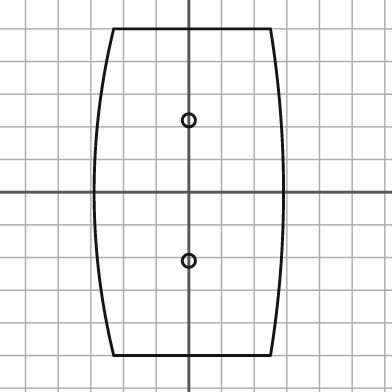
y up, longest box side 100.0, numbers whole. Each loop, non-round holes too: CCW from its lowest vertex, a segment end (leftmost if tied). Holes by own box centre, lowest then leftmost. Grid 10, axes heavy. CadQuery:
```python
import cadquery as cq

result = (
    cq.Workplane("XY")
    .moveTo(-23.0, -50.0)
    .lineTo(25.0, -50.0)
    .threePointArc((29.0, 0.0), (25.0, 50.0))
    .lineTo(-23.0, 50.0)
    .threePointArc((-29.0, 0.0), (-23.0, -50.0))
    .close()
    .moveTo(0.0, -21.0)
    .circle(2.0)
    .moveTo(0.0, 22.0)
    .circle(2.0)
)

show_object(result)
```